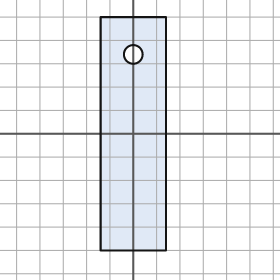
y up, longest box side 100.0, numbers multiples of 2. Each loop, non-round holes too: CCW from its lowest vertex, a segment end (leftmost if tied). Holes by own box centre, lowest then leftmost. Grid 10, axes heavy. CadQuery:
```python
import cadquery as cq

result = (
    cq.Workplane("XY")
    .moveTo(-14.0, -50.0)
    .lineTo(14.0, -50.0)
    .lineTo(14.0, 50.0)
    .lineTo(-14.0, 50.0)
    .close()
    .moveTo(0.0, 34.0)
    .circle(4.0)
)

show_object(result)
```